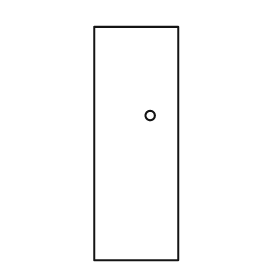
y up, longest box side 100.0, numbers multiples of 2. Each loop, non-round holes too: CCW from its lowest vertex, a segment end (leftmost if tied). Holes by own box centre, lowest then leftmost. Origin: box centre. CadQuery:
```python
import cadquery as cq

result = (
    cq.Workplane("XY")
    .moveTo(-18.0, -50.0)
    .lineTo(18.0, -50.0)
    .lineTo(18.0, 50.0)
    .lineTo(-18.0, 50.0)
    .close()
    .moveTo(6.0, 12.0)
    .circle(2.0)
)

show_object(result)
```